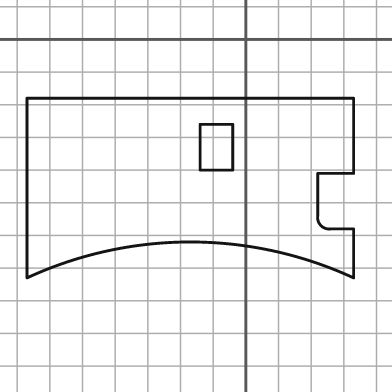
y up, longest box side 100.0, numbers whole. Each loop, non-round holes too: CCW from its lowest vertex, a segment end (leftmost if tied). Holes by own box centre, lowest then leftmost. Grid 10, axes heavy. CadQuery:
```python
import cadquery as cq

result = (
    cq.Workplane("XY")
    .moveTo(-67.0, -73.0)
    .threePointArc((-17.0, -62.0), (33.0, -73.0))
    .lineTo(33.0, -58.0)
    .lineTo(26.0, -58.0)
    .threePointArc((23.0, -57.0), (22.0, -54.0))
    .lineTo(22.0, -41.0)
    .lineTo(33.0, -41.0)
    .lineTo(33.0, -18.0)
    .lineTo(-67.0, -18.0)
    .close()
    .moveTo(-14.0, -40.0)
    .lineTo(-4.0, -40.0)
    .lineTo(-4.0, -26.0)
    .lineTo(-14.0, -26.0)
    .close()
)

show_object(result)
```